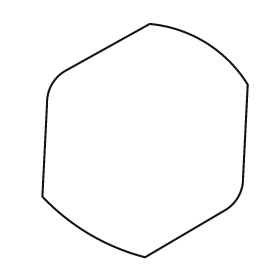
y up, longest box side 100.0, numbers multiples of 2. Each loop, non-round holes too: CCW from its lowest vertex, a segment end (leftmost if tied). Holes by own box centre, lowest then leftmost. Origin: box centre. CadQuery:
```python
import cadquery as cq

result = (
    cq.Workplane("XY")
    .moveTo(0.0, -50.0)
    .lineTo(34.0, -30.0)
    .threePointArc((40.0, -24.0), (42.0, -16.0))
    .lineTo(44.0, 24.0)
    .threePointArc((26.0, 42.0), (2.0, 50.0))
    .lineTo(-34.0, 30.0)
    .threePointArc((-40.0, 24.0), (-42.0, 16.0))
    .lineTo(-44.0, -24.0)
    .threePointArc((-24.0, -40.0), (0.0, -50.0))
    .close()
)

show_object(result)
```